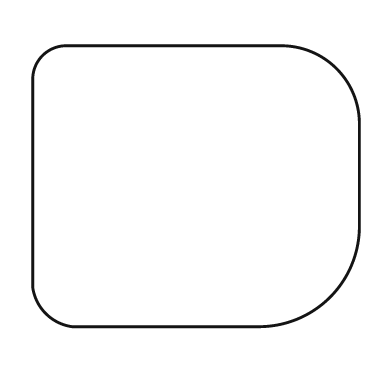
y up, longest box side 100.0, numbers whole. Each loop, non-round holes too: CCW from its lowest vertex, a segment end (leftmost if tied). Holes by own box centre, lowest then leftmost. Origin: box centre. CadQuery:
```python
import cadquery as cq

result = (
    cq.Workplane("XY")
    .moveTo(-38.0, -43.0)
    .lineTo(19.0, -43.0)
    .threePointArc((41.0, -34.0), (50.0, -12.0))
    .lineTo(50.0, 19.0)
    .threePointArc((43.0, 36.0), (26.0, 43.0))
    .lineTo(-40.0, 43.0)
    .threePointArc((-47.0, 40.0), (-50.0, 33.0))
    .lineTo(-50.0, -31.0)
    .threePointArc((-46.0, -39.0), (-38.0, -43.0))
    .close()
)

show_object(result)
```